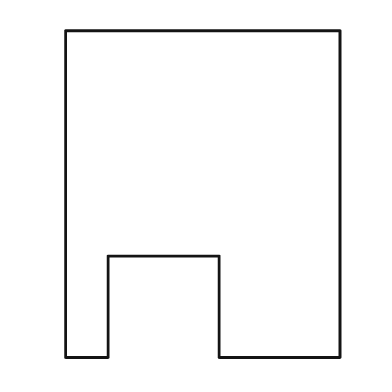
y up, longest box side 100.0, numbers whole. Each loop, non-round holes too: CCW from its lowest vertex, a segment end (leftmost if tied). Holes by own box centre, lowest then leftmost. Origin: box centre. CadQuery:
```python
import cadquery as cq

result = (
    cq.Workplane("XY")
    .moveTo(-42.0, -50.0)
    .lineTo(-29.0, -50.0)
    .lineTo(-29.0, -19.0)
    .lineTo(5.0, -19.0)
    .lineTo(5.0, -50.0)
    .lineTo(42.0, -50.0)
    .lineTo(42.0, 50.0)
    .lineTo(-42.0, 50.0)
    .close()
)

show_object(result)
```